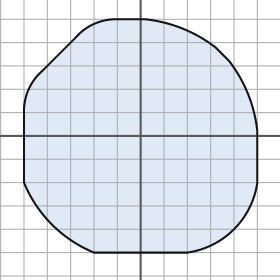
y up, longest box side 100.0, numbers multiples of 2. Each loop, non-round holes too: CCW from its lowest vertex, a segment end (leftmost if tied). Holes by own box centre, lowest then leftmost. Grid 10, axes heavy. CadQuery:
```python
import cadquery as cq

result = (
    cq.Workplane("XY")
    .moveTo(-20.0, -50.0)
    .lineTo(20.0, -50.0)
    .threePointArc((40.0, -40.0), (50.0, -20.0))
    .lineTo(50.0, 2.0)
    .threePointArc((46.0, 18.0), (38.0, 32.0))
    .lineTo(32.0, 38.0)
    .threePointArc((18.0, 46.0), (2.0, 50.0))
    .lineTo(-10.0, 50.0)
    .threePointArc((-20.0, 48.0), (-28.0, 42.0))
    .lineTo(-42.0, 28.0)
    .threePointArc((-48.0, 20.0), (-50.0, 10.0))
    .lineTo(-50.0, -20.0)
    .threePointArc((-38.0, -38.0), (-20.0, -50.0))
    .close()
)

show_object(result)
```